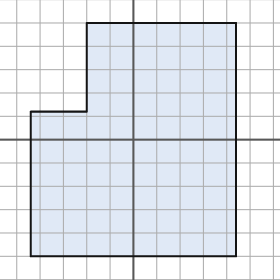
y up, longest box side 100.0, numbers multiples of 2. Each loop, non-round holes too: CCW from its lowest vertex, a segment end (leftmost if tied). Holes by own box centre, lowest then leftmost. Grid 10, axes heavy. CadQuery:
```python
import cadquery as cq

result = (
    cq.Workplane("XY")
    .moveTo(-44.0, -50.0)
    .lineTo(44.0, -50.0)
    .lineTo(44.0, 50.0)
    .lineTo(-20.0, 50.0)
    .lineTo(-20.0, 12.0)
    .lineTo(-44.0, 12.0)
    .close()
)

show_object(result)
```